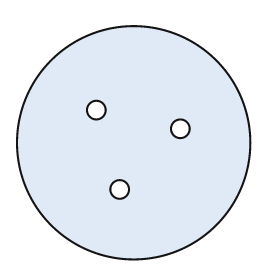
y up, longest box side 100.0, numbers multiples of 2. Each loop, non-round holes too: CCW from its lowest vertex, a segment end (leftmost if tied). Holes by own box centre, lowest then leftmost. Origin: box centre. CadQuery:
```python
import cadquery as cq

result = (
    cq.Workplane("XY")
    .moveTo(0.0, 0.0)
    .circle(50.0)
    .moveTo(-6.0, -20.0)
    .circle(4.0)
    .moveTo(20.0, 6.0)
    .circle(4.0)
    .moveTo(-16.0, 14.0)
    .circle(4.0)
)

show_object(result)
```